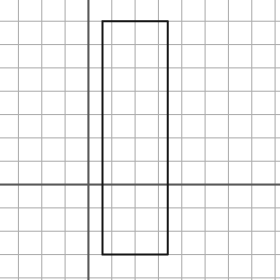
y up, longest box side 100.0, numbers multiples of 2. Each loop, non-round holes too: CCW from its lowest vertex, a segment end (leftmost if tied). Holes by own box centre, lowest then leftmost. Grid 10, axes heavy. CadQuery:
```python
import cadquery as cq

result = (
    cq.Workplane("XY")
    .moveTo(6.0, -30.0)
    .lineTo(34.0, -30.0)
    .lineTo(34.0, 70.0)
    .lineTo(6.0, 70.0)
    .close()
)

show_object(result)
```